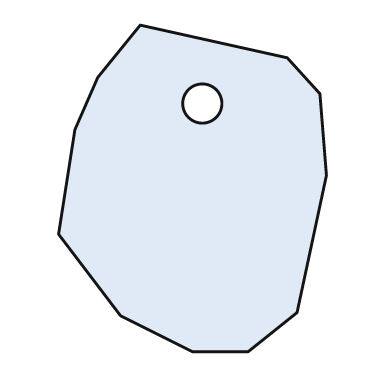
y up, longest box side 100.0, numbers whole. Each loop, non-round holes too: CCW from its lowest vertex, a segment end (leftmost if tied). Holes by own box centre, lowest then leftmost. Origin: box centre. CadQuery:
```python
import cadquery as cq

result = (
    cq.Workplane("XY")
    .moveTo(0.0, -50.0)
    .lineTo(17.0, -50.0)
    .lineTo(32.0, -38.0)
    .lineTo(41.0, 4.0)
    .lineTo(39.0, 29.0)
    .lineTo(29.0, 40.0)
    .lineTo(-16.0, 50.0)
    .lineTo(-29.0, 34.0)
    .lineTo(-36.0, 18.0)
    .lineTo(-41.0, -14.0)
    .lineTo(-22.0, -39.0)
    .close()
    .moveTo(3.0, 26.0)
    .circle(6.0)
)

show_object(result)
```